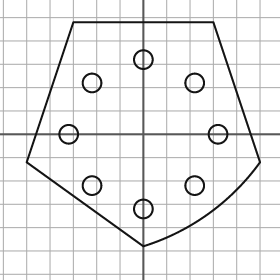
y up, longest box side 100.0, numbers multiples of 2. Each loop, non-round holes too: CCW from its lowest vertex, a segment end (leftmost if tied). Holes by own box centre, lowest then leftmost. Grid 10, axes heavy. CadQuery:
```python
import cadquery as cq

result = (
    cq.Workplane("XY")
    .moveTo(0.0, -48.0)
    .threePointArc((28.0, -34.0), (50.0, -12.0))
    .lineTo(30.0, 48.0)
    .lineTo(-30.0, 48.0)
    .lineTo(-50.0, -12.0)
    .close()
    .moveTo(0.0, -32.0)
    .circle(4.0)
    .moveTo(-22.0, -22.0)
    .circle(4.0)
    .moveTo(22.0, -22.0)
    .circle(4.0)
    .moveTo(-32.0, 0.0)
    .circle(4.0)
    .moveTo(32.0, 0.0)
    .circle(4.0)
    .moveTo(-22.0, 22.0)
    .circle(4.0)
    .moveTo(22.0, 22.0)
    .circle(4.0)
    .moveTo(0.0, 32.0)
    .circle(4.0)
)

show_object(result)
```